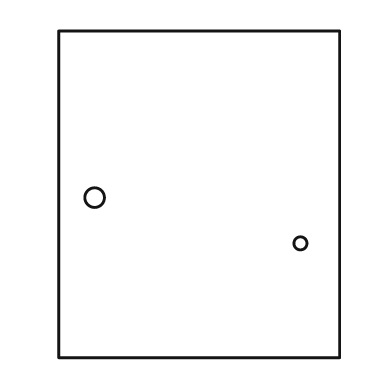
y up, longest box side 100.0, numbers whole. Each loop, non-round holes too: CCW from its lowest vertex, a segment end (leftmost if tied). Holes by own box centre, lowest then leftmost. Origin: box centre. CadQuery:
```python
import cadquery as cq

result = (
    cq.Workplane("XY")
    .moveTo(-43.0, -50.0)
    .lineTo(43.0, -50.0)
    .lineTo(43.0, 50.0)
    .lineTo(-43.0, 50.0)
    .close()
    .moveTo(31.0, -15.0)
    .circle(2.0)
    .moveTo(-32.0, -1.0)
    .circle(3.0)
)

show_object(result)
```